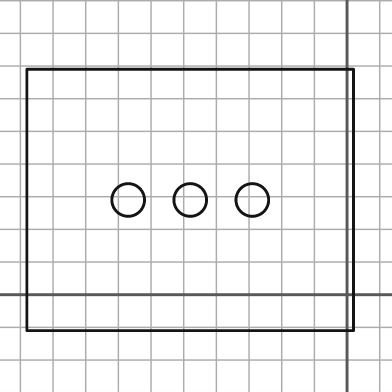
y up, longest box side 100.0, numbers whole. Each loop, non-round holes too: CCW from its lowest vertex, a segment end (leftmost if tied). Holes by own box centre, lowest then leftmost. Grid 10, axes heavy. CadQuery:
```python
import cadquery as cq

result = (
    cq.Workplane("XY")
    .moveTo(-98.0, -11.0)
    .lineTo(2.0, -11.0)
    .lineTo(2.0, 69.0)
    .lineTo(-98.0, 69.0)
    .close()
    .moveTo(-67.0, 29.0)
    .circle(5.0)
    .moveTo(-48.0, 29.0)
    .circle(5.0)
    .moveTo(-29.0, 29.0)
    .circle(5.0)
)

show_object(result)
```